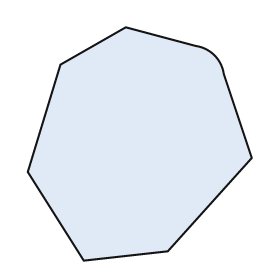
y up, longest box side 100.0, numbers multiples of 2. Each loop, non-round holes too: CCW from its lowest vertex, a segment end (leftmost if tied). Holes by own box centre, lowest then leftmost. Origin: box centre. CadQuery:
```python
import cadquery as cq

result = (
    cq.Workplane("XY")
    .moveTo(-24.0, -50.0)
    .lineTo(12.0, -46.0)
    .lineTo(48.0, -6.0)
    .lineTo(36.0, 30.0)
    .threePointArc((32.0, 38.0), (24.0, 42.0))
    .lineTo(-6.0, 50.0)
    .lineTo(-34.0, 34.0)
    .lineTo(-48.0, -12.0)
    .close()
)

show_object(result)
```